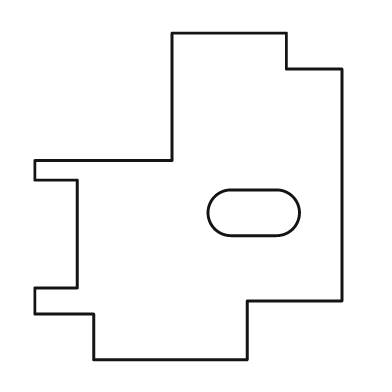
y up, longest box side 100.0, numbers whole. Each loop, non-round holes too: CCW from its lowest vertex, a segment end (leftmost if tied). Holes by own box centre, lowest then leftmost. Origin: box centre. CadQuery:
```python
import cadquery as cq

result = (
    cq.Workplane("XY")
    .moveTo(-29.0, -50.0)
    .lineTo(18.0, -50.0)
    .lineTo(18.0, -32.0)
    .lineTo(47.0, -32.0)
    .lineTo(47.0, 39.0)
    .lineTo(30.0, 39.0)
    .lineTo(30.0, 50.0)
    .lineTo(-5.0, 50.0)
    .lineTo(-5.0, 11.0)
    .lineTo(-47.0, 11.0)
    .lineTo(-47.0, 5.0)
    .lineTo(-34.0, 5.0)
    .lineTo(-34.0, -28.0)
    .lineTo(-47.0, -28.0)
    .lineTo(-47.0, -36.0)
    .lineTo(-29.0, -36.0)
    .close()
    .moveTo(13.0, -12.0)
    .lineTo(27.0, -12.0)
    .threePointArc((34.0, -5.0), (27.0, 2.0))
    .lineTo(13.0, 2.0)
    .threePointArc((6.0, -5.0), (13.0, -12.0))
    .close()
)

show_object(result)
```